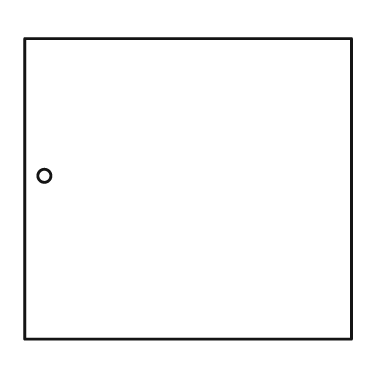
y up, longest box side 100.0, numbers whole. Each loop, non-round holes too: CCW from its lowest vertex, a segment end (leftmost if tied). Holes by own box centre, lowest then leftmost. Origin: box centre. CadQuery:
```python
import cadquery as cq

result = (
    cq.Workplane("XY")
    .moveTo(-50.0, -46.0)
    .lineTo(50.0, -46.0)
    .lineTo(50.0, 46.0)
    .lineTo(-50.0, 46.0)
    .close()
    .moveTo(-44.0, 4.0)
    .circle(2.0)
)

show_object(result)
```